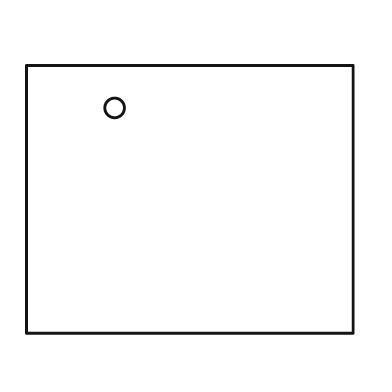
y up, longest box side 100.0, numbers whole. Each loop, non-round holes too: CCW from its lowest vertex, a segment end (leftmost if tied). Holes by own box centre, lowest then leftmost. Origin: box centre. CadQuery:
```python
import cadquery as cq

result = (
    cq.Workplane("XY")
    .moveTo(-50.0, -41.0)
    .lineTo(50.0, -41.0)
    .lineTo(50.0, 41.0)
    .lineTo(-50.0, 41.0)
    .close()
    .moveTo(-23.0, 28.0)
    .circle(3.0)
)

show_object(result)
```